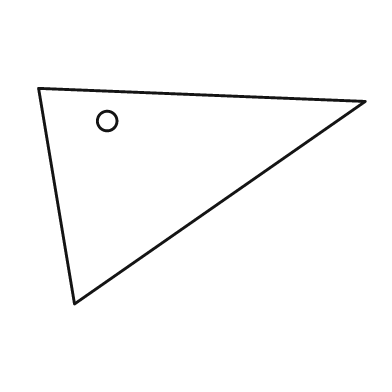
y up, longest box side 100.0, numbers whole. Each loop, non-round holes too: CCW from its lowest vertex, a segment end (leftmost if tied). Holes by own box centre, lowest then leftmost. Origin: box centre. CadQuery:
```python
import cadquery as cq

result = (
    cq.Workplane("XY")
    .moveTo(-39.0, -33.0)
    .lineTo(50.0, 29.0)
    .lineTo(-50.0, 33.0)
    .close()
    .moveTo(-29.0, 23.0)
    .circle(3.0)
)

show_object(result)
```